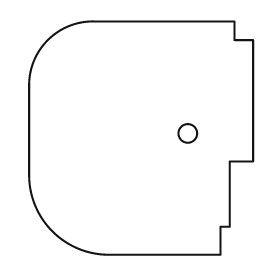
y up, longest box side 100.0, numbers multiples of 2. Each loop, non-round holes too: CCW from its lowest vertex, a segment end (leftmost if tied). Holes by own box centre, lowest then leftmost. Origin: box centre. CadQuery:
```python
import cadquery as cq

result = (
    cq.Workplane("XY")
    .moveTo(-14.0, -50.0)
    .lineTo(34.0, -50.0)
    .lineTo(34.0, -38.0)
    .lineTo(38.0, -38.0)
    .lineTo(38.0, -10.0)
    .lineTo(48.0, -10.0)
    .lineTo(48.0, 42.0)
    .lineTo(40.0, 42.0)
    .lineTo(40.0, 50.0)
    .lineTo(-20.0, 50.0)
    .threePointArc((-40.0, 42.0), (-48.0, 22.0))
    .lineTo(-48.0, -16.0)
    .threePointArc((-38.0, -40.0), (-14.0, -50.0))
    .close()
    .moveTo(20.0, 2.0)
    .circle(4.0)
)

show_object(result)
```